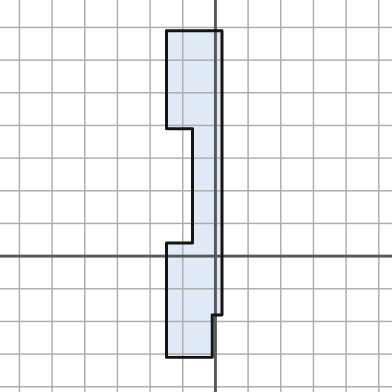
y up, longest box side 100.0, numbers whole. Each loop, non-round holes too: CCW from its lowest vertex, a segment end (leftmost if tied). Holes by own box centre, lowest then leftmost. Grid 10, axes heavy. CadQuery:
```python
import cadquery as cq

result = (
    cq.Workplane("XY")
    .moveTo(-15.0, -31.0)
    .lineTo(-1.0, -31.0)
    .lineTo(-1.0, -18.0)
    .lineTo(2.0, -18.0)
    .lineTo(2.0, 69.0)
    .lineTo(-15.0, 69.0)
    .lineTo(-15.0, 39.0)
    .lineTo(-7.0, 39.0)
    .lineTo(-7.0, 4.0)
    .lineTo(-15.0, 4.0)
    .close()
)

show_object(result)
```